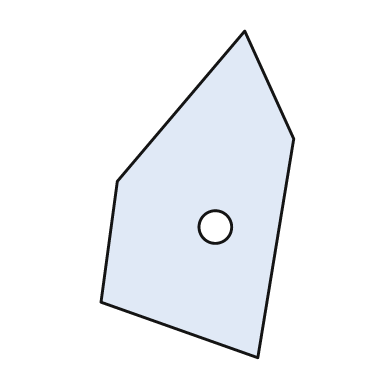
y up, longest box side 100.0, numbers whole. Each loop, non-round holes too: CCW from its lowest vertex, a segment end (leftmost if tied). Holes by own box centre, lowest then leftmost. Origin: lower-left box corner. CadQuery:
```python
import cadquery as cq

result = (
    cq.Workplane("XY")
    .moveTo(48.0, 0.0)
    .lineTo(59.0, 67.0)
    .lineTo(44.0, 100.0)
    .lineTo(5.0, 54.0)
    .lineTo(0.0, 17.0)
    .close()
    .moveTo(35.0, 40.0)
    .circle(5.0)
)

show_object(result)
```